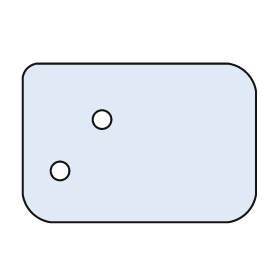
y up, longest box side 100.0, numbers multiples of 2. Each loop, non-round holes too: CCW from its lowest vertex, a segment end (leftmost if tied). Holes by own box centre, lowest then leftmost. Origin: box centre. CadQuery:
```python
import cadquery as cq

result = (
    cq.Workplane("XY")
    .moveTo(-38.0, -34.0)
    .lineTo(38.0, -34.0)
    .threePointArc((46.0, -30.0), (50.0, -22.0))
    .lineTo(50.0, 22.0)
    .threePointArc((46.0, 30.0), (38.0, 34.0))
    .lineTo(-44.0, 34.0)
    .threePointArc((-48.0, 32.0), (-50.0, 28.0))
    .lineTo(-50.0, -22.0)
    .threePointArc((-46.0, -30.0), (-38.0, -34.0))
    .close()
    .moveTo(-34.0, -12.0)
    .circle(4.0)
    .moveTo(-16.0, 10.0)
    .circle(4.0)
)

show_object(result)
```